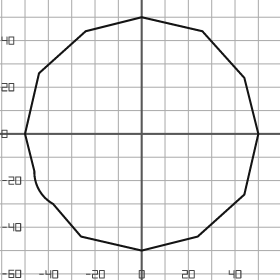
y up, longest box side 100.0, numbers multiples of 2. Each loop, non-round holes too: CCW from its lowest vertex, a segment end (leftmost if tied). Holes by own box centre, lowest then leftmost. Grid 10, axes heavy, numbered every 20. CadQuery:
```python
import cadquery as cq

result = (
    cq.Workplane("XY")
    .moveTo(0.0, -50.0)
    .lineTo(24.0, -44.0)
    .lineTo(44.0, -26.0)
    .lineTo(50.0, 0.0)
    .lineTo(44.0, 24.0)
    .lineTo(26.0, 44.0)
    .lineTo(0.0, 50.0)
    .lineTo(-24.0, 44.0)
    .lineTo(-44.0, 26.0)
    .lineTo(-50.0, 0.0)
    .lineTo(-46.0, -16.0)
    .threePointArc((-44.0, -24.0), (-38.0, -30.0))
    .lineTo(-26.0, -44.0)
    .close()
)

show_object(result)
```